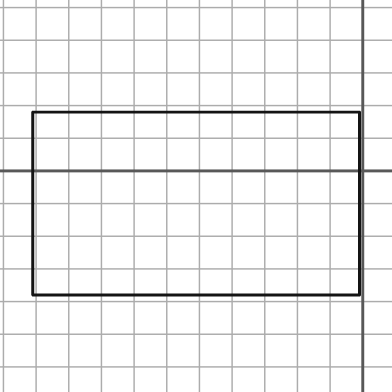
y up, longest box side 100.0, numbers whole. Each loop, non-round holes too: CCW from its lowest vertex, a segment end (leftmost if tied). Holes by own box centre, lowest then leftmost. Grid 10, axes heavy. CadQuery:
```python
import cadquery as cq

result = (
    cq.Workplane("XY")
    .moveTo(-101.0, -38.0)
    .lineTo(-1.0, -38.0)
    .lineTo(-1.0, 18.0)
    .lineTo(-101.0, 18.0)
    .close()
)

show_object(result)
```